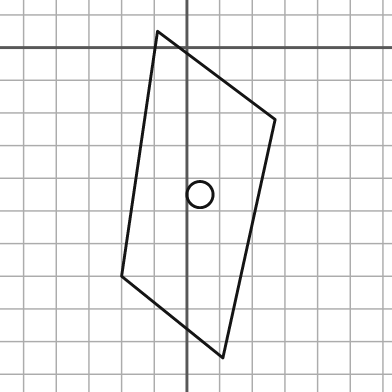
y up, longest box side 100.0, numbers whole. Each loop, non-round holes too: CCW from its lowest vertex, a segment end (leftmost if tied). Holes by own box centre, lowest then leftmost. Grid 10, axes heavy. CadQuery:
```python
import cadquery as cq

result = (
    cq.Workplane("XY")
    .moveTo(11.0, -95.0)
    .lineTo(27.0, -22.0)
    .lineTo(-9.0, 5.0)
    .lineTo(-20.0, -70.0)
    .close()
    .moveTo(4.0, -45.0)
    .circle(4.0)
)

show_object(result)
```